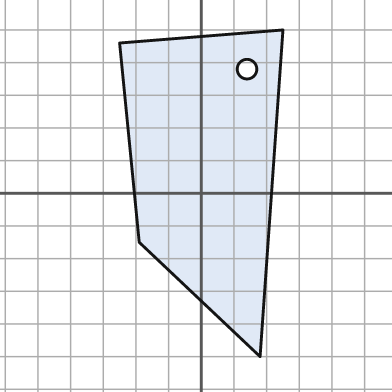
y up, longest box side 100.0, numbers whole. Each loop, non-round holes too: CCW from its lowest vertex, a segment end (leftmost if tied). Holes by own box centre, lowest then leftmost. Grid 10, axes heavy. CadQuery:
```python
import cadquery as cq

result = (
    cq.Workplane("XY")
    .moveTo(18.0, -50.0)
    .lineTo(25.0, 50.0)
    .lineTo(-25.0, 46.0)
    .lineTo(-19.0, -15.0)
    .close()
    .moveTo(14.0, 38.0)
    .circle(3.0)
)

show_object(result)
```